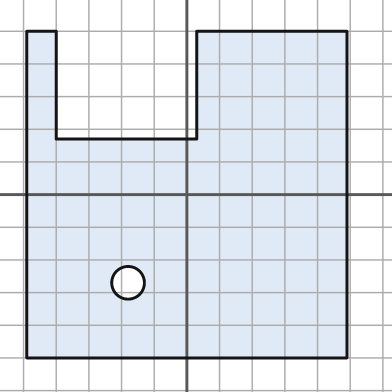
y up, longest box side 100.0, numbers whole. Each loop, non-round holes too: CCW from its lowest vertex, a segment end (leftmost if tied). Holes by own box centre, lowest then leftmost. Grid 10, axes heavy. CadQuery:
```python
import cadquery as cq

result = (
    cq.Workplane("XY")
    .moveTo(-49.0, -50.0)
    .lineTo(49.0, -50.0)
    .lineTo(49.0, 50.0)
    .lineTo(3.0, 50.0)
    .lineTo(3.0, 17.0)
    .lineTo(-40.0, 17.0)
    .lineTo(-40.0, 50.0)
    .lineTo(-49.0, 50.0)
    .close()
    .moveTo(-18.0, -27.0)
    .circle(5.0)
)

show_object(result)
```